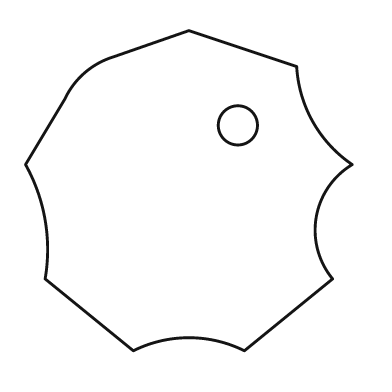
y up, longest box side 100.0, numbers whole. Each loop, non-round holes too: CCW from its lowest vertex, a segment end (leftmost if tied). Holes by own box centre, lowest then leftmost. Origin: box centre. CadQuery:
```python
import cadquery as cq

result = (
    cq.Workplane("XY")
    .moveTo(-17.0, -49.0)
    .threePointArc((0.0, -45.0), (17.0, -49.0))
    .lineTo(44.0, -27.0)
    .threePointArc((39.0, -8.0), (50.0, 8.0))
    .threePointArc((38.0, 21.0), (33.0, 38.0))
    .lineTo(0.0, 49.0)
    .lineTo(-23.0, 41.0)
    .threePointArc((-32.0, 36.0), (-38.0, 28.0))
    .lineTo(-50.0, 8.0)
    .threePointArc((-44.0, -9.0), (-44.0, -27.0))
    .close()
    .moveTo(15.0, 20.0)
    .circle(6.0)
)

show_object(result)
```